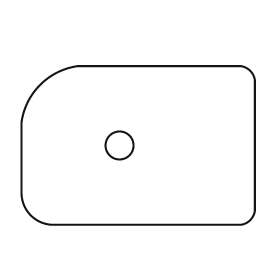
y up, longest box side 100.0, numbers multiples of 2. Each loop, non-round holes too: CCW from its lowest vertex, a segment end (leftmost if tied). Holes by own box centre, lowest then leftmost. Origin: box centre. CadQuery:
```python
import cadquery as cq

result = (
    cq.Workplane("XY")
    .moveTo(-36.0, -34.0)
    .lineTo(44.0, -34.0)
    .threePointArc((48.0, -32.0), (50.0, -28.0))
    .lineTo(50.0, 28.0)
    .threePointArc((48.0, 32.0), (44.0, 34.0))
    .lineTo(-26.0, 34.0)
    .threePointArc((-42.0, 26.0), (-50.0, 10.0))
    .lineTo(-50.0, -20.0)
    .threePointArc((-46.0, -30.0), (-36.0, -34.0))
    .close()
    .moveTo(-8.0, 0.0)
    .circle(6.0)
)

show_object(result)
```